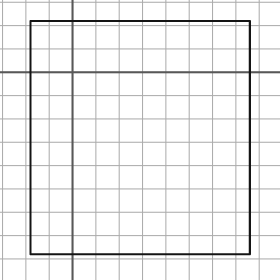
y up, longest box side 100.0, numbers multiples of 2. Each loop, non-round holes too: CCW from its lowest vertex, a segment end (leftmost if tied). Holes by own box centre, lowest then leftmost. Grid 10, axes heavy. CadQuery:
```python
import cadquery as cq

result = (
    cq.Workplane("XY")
    .moveTo(-18.0, -78.0)
    .lineTo(76.0, -78.0)
    .lineTo(76.0, 22.0)
    .lineTo(-18.0, 22.0)
    .close()
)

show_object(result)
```